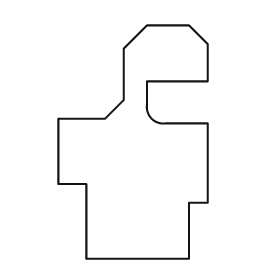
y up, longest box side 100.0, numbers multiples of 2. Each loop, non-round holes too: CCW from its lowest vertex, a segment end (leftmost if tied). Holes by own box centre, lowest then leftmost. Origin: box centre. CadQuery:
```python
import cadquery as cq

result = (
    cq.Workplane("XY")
    .moveTo(-20.0, -50.0)
    .lineTo(24.0, -50.0)
    .lineTo(24.0, -26.0)
    .lineTo(32.0, -26.0)
    .lineTo(32.0, 8.0)
    .lineTo(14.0, 8.0)
    .threePointArc((8.0, 10.0), (6.0, 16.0))
    .lineTo(6.0, 26.0)
    .lineTo(32.0, 26.0)
    .lineTo(32.0, 42.0)
    .lineTo(24.0, 50.0)
    .lineTo(6.0, 50.0)
    .lineTo(-4.0, 40.0)
    .lineTo(-4.0, 18.0)
    .lineTo(-12.0, 10.0)
    .lineTo(-32.0, 10.0)
    .lineTo(-32.0, -18.0)
    .lineTo(-20.0, -18.0)
    .close()
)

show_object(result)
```